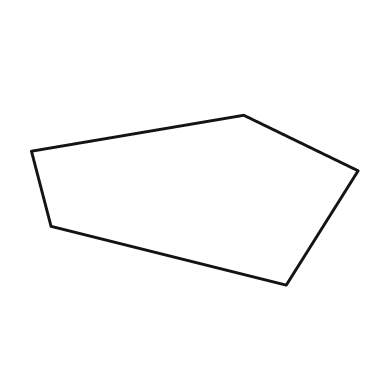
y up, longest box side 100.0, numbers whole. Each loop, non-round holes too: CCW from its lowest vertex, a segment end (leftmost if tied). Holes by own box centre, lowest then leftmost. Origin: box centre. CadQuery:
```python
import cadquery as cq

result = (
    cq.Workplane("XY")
    .moveTo(28.0, -26.0)
    .lineTo(50.0, 9.0)
    .lineTo(15.0, 26.0)
    .lineTo(-50.0, 15.0)
    .lineTo(-44.0, -8.0)
    .close()
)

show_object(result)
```